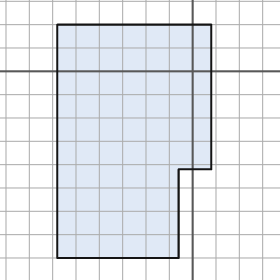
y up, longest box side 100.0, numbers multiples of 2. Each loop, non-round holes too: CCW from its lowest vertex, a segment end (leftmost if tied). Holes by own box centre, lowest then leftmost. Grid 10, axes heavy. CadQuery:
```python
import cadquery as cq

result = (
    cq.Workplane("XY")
    .moveTo(-58.0, -80.0)
    .lineTo(-6.0, -80.0)
    .lineTo(-6.0, -42.0)
    .lineTo(8.0, -42.0)
    .lineTo(8.0, 20.0)
    .lineTo(-58.0, 20.0)
    .close()
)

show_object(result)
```